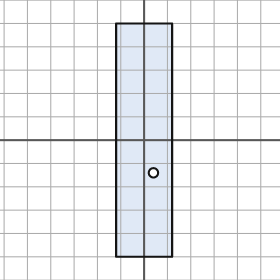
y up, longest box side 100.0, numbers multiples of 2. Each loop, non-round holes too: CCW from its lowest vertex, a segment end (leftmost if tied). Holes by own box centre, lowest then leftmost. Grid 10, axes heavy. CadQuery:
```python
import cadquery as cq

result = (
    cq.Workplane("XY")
    .moveTo(-12.0, -50.0)
    .lineTo(12.0, -50.0)
    .lineTo(12.0, 50.0)
    .lineTo(-12.0, 50.0)
    .close()
    .moveTo(4.0, -14.0)
    .circle(2.0)
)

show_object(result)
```